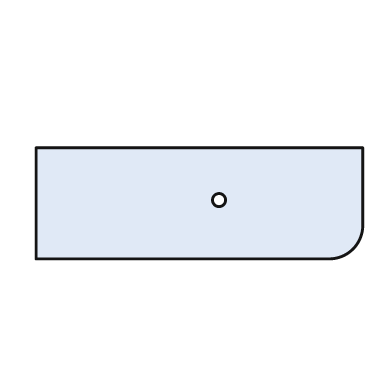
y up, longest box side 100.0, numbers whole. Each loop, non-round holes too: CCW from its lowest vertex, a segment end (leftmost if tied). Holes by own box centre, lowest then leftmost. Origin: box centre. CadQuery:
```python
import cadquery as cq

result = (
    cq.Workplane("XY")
    .moveTo(-50.0, -17.0)
    .lineTo(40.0, -17.0)
    .threePointArc((47.0, -14.0), (50.0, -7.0))
    .lineTo(50.0, 17.0)
    .lineTo(-50.0, 17.0)
    .close()
    .moveTo(6.0, 1.0)
    .circle(2.0)
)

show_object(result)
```